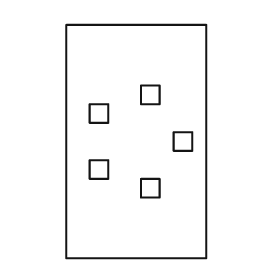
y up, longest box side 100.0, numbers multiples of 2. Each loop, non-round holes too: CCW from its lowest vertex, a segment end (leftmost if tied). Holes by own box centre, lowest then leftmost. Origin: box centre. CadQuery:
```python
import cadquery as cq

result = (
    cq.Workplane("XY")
    .moveTo(-30.0, -50.0)
    .lineTo(30.0, -50.0)
    .lineTo(30.0, 50.0)
    .lineTo(-30.0, 50.0)
    .close()
    .moveTo(2.0, -24.0)
    .lineTo(10.0, -24.0)
    .lineTo(10.0, -16.0)
    .lineTo(2.0, -16.0)
    .close()
    .moveTo(-20.0, -16.0)
    .lineTo(-12.0, -16.0)
    .lineTo(-12.0, -8.0)
    .lineTo(-20.0, -8.0)
    .close()
    .moveTo(16.0, -4.0)
    .lineTo(24.0, -4.0)
    .lineTo(24.0, 4.0)
    .lineTo(16.0, 4.0)
    .close()
    .moveTo(-20.0, 8.0)
    .lineTo(-12.0, 8.0)
    .lineTo(-12.0, 16.0)
    .lineTo(-20.0, 16.0)
    .close()
    .moveTo(2.0, 16.0)
    .lineTo(10.0, 16.0)
    .lineTo(10.0, 24.0)
    .lineTo(2.0, 24.0)
    .close()
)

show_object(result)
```